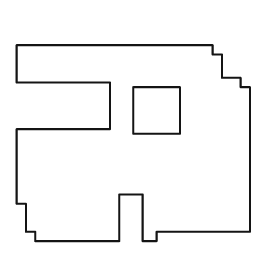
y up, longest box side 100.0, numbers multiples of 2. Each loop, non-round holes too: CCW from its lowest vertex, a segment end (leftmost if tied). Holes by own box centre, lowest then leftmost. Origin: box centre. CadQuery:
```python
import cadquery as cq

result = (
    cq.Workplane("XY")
    .moveTo(-42.0, -42.0)
    .lineTo(-6.0, -42.0)
    .lineTo(-6.0, -22.0)
    .lineTo(4.0, -22.0)
    .lineTo(4.0, -42.0)
    .lineTo(10.0, -42.0)
    .lineTo(10.0, -38.0)
    .lineTo(50.0, -38.0)
    .lineTo(50.0, 24.0)
    .lineTo(46.0, 24.0)
    .lineTo(46.0, 28.0)
    .lineTo(38.0, 28.0)
    .lineTo(38.0, 38.0)
    .lineTo(34.0, 38.0)
    .lineTo(34.0, 42.0)
    .lineTo(-50.0, 42.0)
    .lineTo(-50.0, 26.0)
    .lineTo(-10.0, 26.0)
    .lineTo(-10.0, 6.0)
    .lineTo(-50.0, 6.0)
    .lineTo(-50.0, -26.0)
    .lineTo(-46.0, -26.0)
    .lineTo(-46.0, -38.0)
    .lineTo(-42.0, -38.0)
    .close()
    .moveTo(0.0, 4.0)
    .lineTo(20.0, 4.0)
    .lineTo(20.0, 24.0)
    .lineTo(0.0, 24.0)
    .close()
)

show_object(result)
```